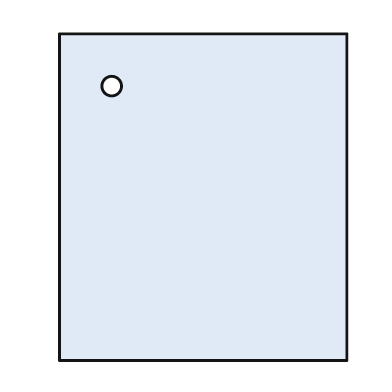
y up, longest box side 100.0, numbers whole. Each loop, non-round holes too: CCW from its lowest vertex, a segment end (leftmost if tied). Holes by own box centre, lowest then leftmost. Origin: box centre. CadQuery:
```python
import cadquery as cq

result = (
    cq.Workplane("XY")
    .moveTo(-44.0, -50.0)
    .lineTo(44.0, -50.0)
    .lineTo(44.0, 50.0)
    .lineTo(-44.0, 50.0)
    .close()
    .moveTo(-28.0, 34.0)
    .circle(3.0)
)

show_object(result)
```